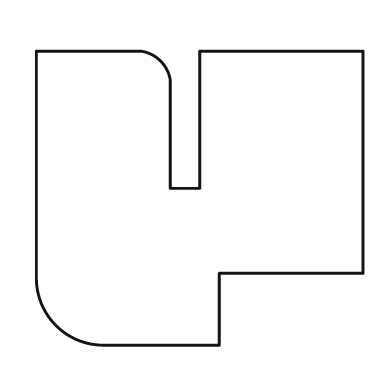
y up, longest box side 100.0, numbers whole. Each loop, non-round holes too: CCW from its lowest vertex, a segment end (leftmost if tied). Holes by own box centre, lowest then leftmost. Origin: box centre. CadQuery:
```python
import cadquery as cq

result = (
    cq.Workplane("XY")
    .moveTo(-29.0, -45.0)
    .lineTo(6.0, -45.0)
    .lineTo(6.0, -23.0)
    .lineTo(50.0, -23.0)
    .lineTo(50.0, 45.0)
    .lineTo(0.0, 45.0)
    .lineTo(0.0, 3.0)
    .lineTo(-9.0, 3.0)
    .lineTo(-9.0, 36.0)
    .threePointArc((-12.0, 42.0), (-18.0, 45.0))
    .lineTo(-50.0, 45.0)
    .lineTo(-50.0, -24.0)
    .threePointArc((-44.0, -39.0), (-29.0, -45.0))
    .close()
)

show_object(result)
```